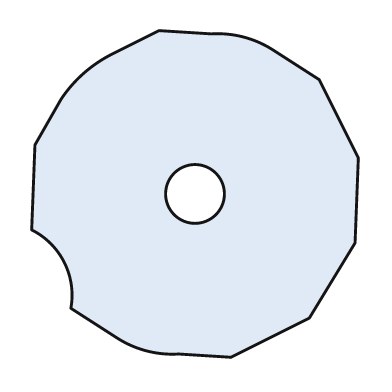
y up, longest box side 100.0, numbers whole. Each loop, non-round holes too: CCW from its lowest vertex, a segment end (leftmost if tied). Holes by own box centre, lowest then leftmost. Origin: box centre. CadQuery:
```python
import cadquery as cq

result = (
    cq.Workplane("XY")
    .moveTo(11.0, -50.0)
    .lineTo(35.0, -38.0)
    .lineTo(49.0, -15.0)
    .lineTo(50.0, 11.0)
    .lineTo(38.0, 35.0)
    .lineTo(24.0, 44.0)
    .threePointArc((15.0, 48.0), (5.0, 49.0))
    .lineTo(-11.0, 50.0)
    .lineTo(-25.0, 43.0)
    .threePointArc((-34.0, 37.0), (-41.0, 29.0))
    .lineTo(-49.0, 15.0)
    .lineTo(-50.0, -11.0)
    .threePointArc((-40.0, -21.0), (-38.0, -35.0))
    .lineTo(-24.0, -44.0)
    .threePointArc((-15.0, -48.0), (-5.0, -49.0))
    .close()
    .moveTo(0.0, 0.0)
    .circle(9.0)
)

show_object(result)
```